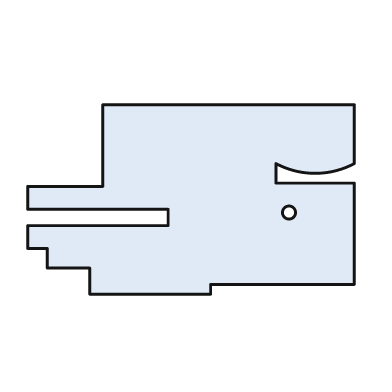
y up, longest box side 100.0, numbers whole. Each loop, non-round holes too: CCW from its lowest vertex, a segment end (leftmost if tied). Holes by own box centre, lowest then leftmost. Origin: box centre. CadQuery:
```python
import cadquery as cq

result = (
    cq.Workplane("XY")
    .moveTo(-31.0, -29.0)
    .lineTo(6.0, -29.0)
    .lineTo(6.0, -26.0)
    .lineTo(50.0, -26.0)
    .lineTo(50.0, 5.0)
    .lineTo(26.0, 5.0)
    .lineTo(26.0, 11.0)
    .threePointArc((38.0, 8.0), (50.0, 11.0))
    .lineTo(50.0, 29.0)
    .lineTo(-27.0, 29.0)
    .lineTo(-27.0, 4.0)
    .lineTo(-50.0, 4.0)
    .lineTo(-50.0, -3.0)
    .lineTo(-7.0, -3.0)
    .lineTo(-7.0, -8.0)
    .lineTo(-50.0, -8.0)
    .lineTo(-50.0, -15.0)
    .lineTo(-44.0, -15.0)
    .lineTo(-44.0, -21.0)
    .lineTo(-31.0, -21.0)
    .close()
    .moveTo(30.0, -4.0)
    .circle(2.0)
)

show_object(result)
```